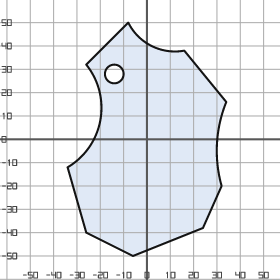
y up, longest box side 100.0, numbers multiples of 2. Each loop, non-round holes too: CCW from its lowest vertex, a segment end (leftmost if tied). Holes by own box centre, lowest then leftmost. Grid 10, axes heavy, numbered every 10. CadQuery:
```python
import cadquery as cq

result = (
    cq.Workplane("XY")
    .moveTo(-6.0, -50.0)
    .lineTo(24.0, -38.0)
    .lineTo(32.0, -20.0)
    .threePointArc((30.0, -2.0), (34.0, 16.0))
    .lineTo(16.0, 38.0)
    .threePointArc((2.0, 40.0), (-8.0, 50.0))
    .lineTo(-26.0, 32.0)
    .threePointArc((-20.0, 8.0), (-34.0, -12.0))
    .lineTo(-26.0, -40.0)
    .close()
    .moveTo(-14.0, 28.0)
    .circle(4.0)
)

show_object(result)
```